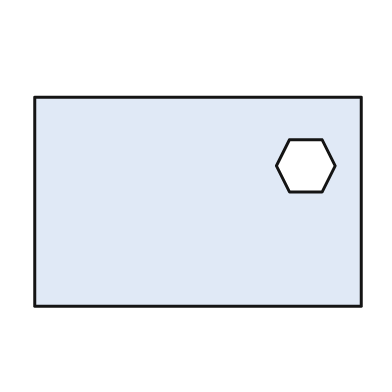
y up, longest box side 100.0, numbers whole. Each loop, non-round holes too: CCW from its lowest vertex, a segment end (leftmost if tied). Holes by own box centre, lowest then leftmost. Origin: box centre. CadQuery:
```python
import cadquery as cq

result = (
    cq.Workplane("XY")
    .moveTo(-50.0, -32.0)
    .lineTo(50.0, -32.0)
    .lineTo(50.0, 32.0)
    .lineTo(-50.0, 32.0)
    .close()
    .moveTo(28.0, 3.0)
    .lineTo(38.0, 3.0)
    .lineTo(42.0, 11.0)
    .lineTo(38.0, 19.0)
    .lineTo(28.0, 19.0)
    .lineTo(24.0, 11.0)
    .close()
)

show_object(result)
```